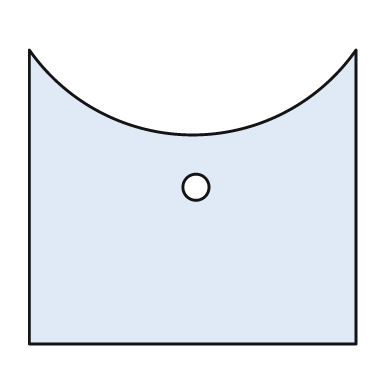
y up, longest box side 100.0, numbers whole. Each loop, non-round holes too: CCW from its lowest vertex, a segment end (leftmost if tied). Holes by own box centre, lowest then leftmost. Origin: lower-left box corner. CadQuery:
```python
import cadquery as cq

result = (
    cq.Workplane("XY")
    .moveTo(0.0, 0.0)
    .lineTo(100.0, 0.0)
    .lineTo(100.0, 90.0)
    .threePointArc((50.0, 64.0), (0.0, 90.0))
    .close()
    .moveTo(51.0, 48.0)
    .circle(4.0)
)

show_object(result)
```